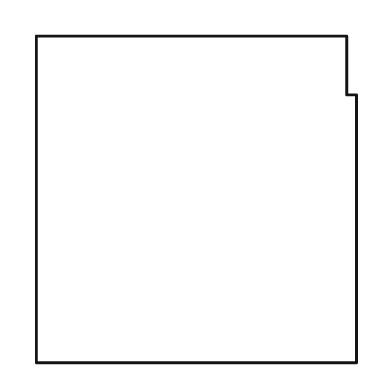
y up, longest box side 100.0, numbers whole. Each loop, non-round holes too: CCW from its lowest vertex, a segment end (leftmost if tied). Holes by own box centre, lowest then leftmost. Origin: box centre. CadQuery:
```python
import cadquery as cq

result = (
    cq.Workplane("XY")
    .moveTo(-49.0, -50.0)
    .lineTo(49.0, -50.0)
    .lineTo(49.0, 32.0)
    .lineTo(46.0, 32.0)
    .lineTo(46.0, 50.0)
    .lineTo(-49.0, 50.0)
    .close()
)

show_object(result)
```